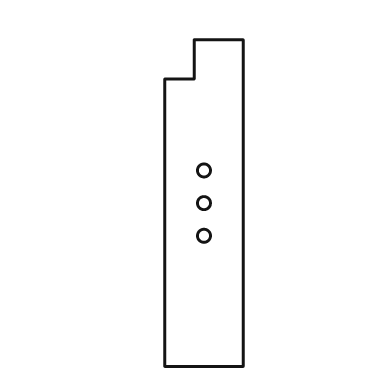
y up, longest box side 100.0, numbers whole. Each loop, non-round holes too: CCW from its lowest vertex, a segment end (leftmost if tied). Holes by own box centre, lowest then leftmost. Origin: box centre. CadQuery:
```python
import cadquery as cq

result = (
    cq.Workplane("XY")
    .moveTo(-12.0, -50.0)
    .lineTo(12.0, -50.0)
    .lineTo(12.0, 50.0)
    .lineTo(-3.0, 50.0)
    .lineTo(-3.0, 38.0)
    .lineTo(-12.0, 38.0)
    .close()
    .moveTo(0.0, -10.0)
    .circle(2.0)
    .moveTo(0.0, 0.0)
    .circle(2.0)
    .moveTo(0.0, 10.0)
    .circle(2.0)
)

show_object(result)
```